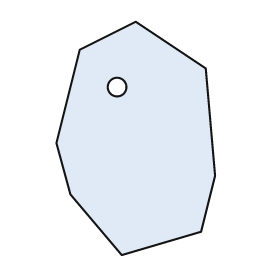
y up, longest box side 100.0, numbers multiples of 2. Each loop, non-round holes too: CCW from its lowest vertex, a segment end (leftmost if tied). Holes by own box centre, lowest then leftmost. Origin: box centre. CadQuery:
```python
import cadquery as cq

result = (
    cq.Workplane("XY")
    .moveTo(-6.0, -50.0)
    .lineTo(28.0, -40.0)
    .lineTo(34.0, -16.0)
    .lineTo(30.0, 30.0)
    .lineTo(0.0, 50.0)
    .lineTo(-24.0, 38.0)
    .lineTo(-34.0, -2.0)
    .lineTo(-28.0, -24.0)
    .close()
    .moveTo(-8.0, 22.0)
    .circle(4.0)
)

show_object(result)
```